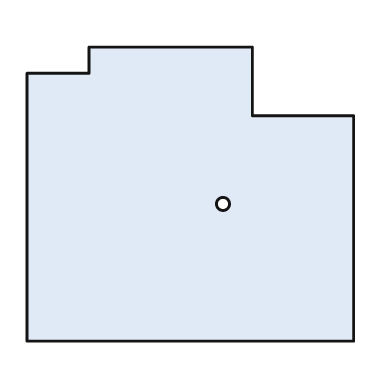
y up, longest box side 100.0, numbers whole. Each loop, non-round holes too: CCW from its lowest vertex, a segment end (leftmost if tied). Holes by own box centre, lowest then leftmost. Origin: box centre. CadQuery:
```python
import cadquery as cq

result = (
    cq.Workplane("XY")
    .moveTo(-50.0, -45.0)
    .lineTo(50.0, -45.0)
    .lineTo(50.0, 24.0)
    .lineTo(19.0, 24.0)
    .lineTo(19.0, 45.0)
    .lineTo(-31.0, 45.0)
    .lineTo(-31.0, 37.0)
    .lineTo(-50.0, 37.0)
    .close()
    .moveTo(10.0, -3.0)
    .circle(2.0)
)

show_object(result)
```